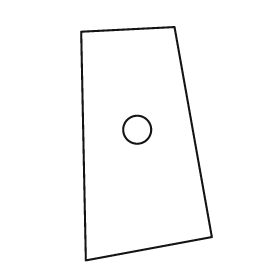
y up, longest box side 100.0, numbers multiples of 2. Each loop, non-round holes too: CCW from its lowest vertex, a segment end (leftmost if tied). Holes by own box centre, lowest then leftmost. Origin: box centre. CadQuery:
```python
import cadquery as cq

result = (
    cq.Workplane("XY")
    .moveTo(-26.0, -50.0)
    .lineTo(28.0, -40.0)
    .lineTo(12.0, 50.0)
    .lineTo(-28.0, 48.0)
    .close()
    .moveTo(-4.0, 6.0)
    .circle(6.0)
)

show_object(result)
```